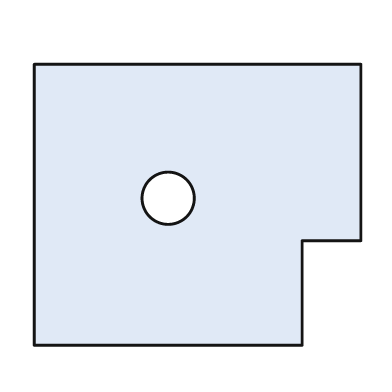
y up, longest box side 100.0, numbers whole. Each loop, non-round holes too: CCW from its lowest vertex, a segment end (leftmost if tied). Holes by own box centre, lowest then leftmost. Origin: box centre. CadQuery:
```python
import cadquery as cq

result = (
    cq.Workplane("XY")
    .moveTo(-50.0, -43.0)
    .lineTo(32.0, -43.0)
    .lineTo(32.0, -11.0)
    .lineTo(50.0, -11.0)
    .lineTo(50.0, 43.0)
    .lineTo(-50.0, 43.0)
    .close()
    .moveTo(-9.0, 2.0)
    .circle(8.0)
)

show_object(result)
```